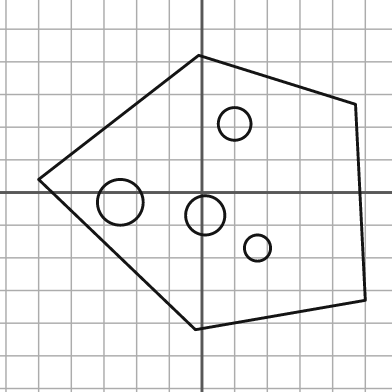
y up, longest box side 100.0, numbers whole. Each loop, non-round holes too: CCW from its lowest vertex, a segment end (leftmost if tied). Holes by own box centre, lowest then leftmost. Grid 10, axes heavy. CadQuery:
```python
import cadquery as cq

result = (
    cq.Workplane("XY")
    .moveTo(-2.0, -42.0)
    .lineTo(50.0, -33.0)
    .lineTo(47.0, 27.0)
    .lineTo(-1.0, 42.0)
    .lineTo(-50.0, 4.0)
    .close()
    .moveTo(17.0, -17.0)
    .circle(4.0)
    .moveTo(1.0, -7.0)
    .circle(6.0)
    .moveTo(-25.0, -3.0)
    .circle(7.0)
    .moveTo(10.0, 21.0)
    .circle(5.0)
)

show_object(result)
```